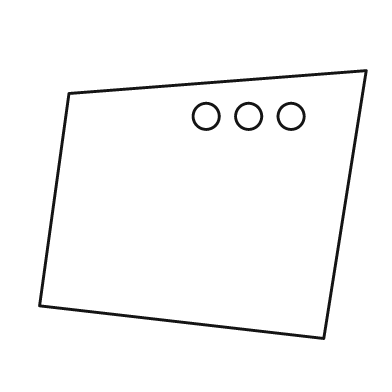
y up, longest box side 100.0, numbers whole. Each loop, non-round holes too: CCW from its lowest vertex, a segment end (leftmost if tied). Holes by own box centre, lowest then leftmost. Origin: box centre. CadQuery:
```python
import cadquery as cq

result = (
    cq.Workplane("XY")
    .moveTo(37.0, -41.0)
    .lineTo(50.0, 41.0)
    .lineTo(-41.0, 34.0)
    .lineTo(-50.0, -31.0)
    .close()
    .moveTo(1.0, 27.0)
    .circle(4.0)
    .moveTo(14.0, 27.0)
    .circle(4.0)
    .moveTo(27.0, 27.0)
    .circle(4.0)
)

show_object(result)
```